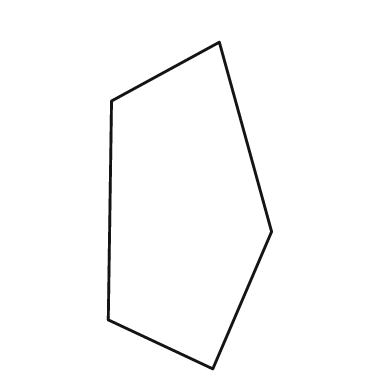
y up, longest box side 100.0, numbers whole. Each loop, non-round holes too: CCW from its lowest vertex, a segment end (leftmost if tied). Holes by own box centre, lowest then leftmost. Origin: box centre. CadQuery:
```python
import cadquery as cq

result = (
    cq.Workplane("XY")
    .moveTo(7.0, -50.0)
    .lineTo(25.0, -8.0)
    .lineTo(9.0, 50.0)
    .lineTo(-24.0, 32.0)
    .lineTo(-25.0, -35.0)
    .close()
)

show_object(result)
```